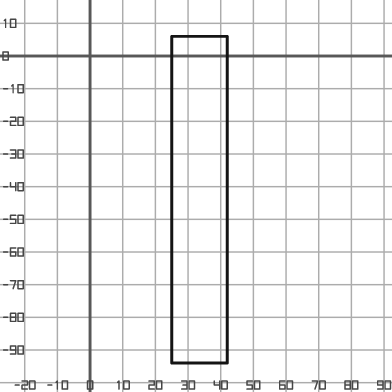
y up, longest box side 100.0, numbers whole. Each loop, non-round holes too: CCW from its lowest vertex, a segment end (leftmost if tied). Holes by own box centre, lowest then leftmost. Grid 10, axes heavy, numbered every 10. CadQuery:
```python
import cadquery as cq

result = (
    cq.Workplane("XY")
    .moveTo(25.0, -94.0)
    .lineTo(42.0, -94.0)
    .lineTo(42.0, 6.0)
    .lineTo(25.0, 6.0)
    .close()
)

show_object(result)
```